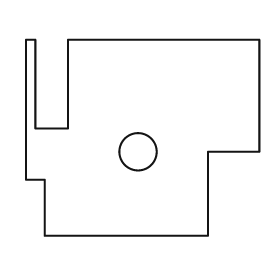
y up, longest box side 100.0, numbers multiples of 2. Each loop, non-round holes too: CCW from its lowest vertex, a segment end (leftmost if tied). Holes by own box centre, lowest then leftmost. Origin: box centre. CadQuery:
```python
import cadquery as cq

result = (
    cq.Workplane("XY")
    .moveTo(-42.0, -42.0)
    .lineTo(28.0, -42.0)
    .lineTo(28.0, -6.0)
    .lineTo(50.0, -6.0)
    .lineTo(50.0, 42.0)
    .lineTo(-32.0, 42.0)
    .lineTo(-32.0, 4.0)
    .lineTo(-46.0, 4.0)
    .lineTo(-46.0, 42.0)
    .lineTo(-50.0, 42.0)
    .lineTo(-50.0, -18.0)
    .lineTo(-42.0, -18.0)
    .close()
    .moveTo(-2.0, -6.0)
    .circle(8.0)
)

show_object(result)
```